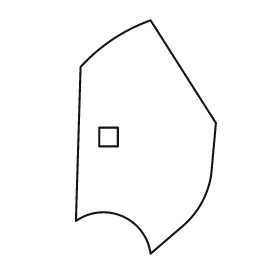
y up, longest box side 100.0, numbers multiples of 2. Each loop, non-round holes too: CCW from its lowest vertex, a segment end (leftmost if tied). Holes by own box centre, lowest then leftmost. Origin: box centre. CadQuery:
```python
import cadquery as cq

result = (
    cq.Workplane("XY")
    .moveTo(2.0, -50.0)
    .lineTo(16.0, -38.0)
    .threePointArc((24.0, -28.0), (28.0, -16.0))
    .lineTo(30.0, 6.0)
    .lineTo(2.0, 50.0)
    .threePointArc((-14.0, 42.0), (-28.0, 30.0))
    .lineTo(-30.0, -36.0)
    .threePointArc((-10.0, -34.0), (2.0, -50.0))
    .close()
    .moveTo(-20.0, -4.0)
    .lineTo(-12.0, -4.0)
    .lineTo(-12.0, 4.0)
    .lineTo(-20.0, 4.0)
    .close()
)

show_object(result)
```